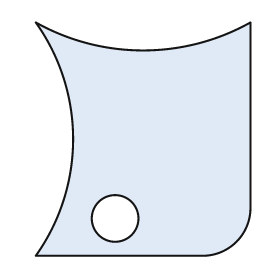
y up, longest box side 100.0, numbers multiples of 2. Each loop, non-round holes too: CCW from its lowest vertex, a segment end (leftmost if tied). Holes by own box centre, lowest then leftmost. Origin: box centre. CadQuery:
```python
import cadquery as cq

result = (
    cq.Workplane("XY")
    .moveTo(-46.0, -50.0)
    .lineTo(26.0, -50.0)
    .threePointArc((40.0, -44.0), (46.0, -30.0))
    .lineTo(46.0, 50.0)
    .threePointArc((0.0, 38.0), (-46.0, 50.0))
    .threePointArc((-30.0, 0.0), (-46.0, -50.0))
    .close()
    .moveTo(-12.0, -34.0)
    .circle(10.0)
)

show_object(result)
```